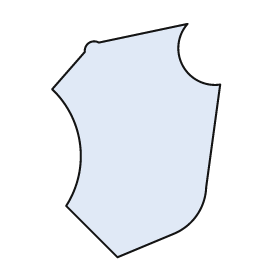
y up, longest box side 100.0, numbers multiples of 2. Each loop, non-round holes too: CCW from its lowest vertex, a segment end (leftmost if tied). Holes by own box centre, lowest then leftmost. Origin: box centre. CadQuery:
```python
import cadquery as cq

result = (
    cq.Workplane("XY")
    .moveTo(-8.0, -50.0)
    .lineTo(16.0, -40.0)
    .threePointArc((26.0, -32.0), (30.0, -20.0))
    .lineTo(36.0, 24.0)
    .threePointArc((20.0, 32.0), (22.0, 50.0))
    .lineTo(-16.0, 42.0)
    .threePointArc((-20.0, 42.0), (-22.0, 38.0))
    .lineTo(-36.0, 22.0)
    .threePointArc((-24.0, -2.0), (-30.0, -28.0))
    .close()
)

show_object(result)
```